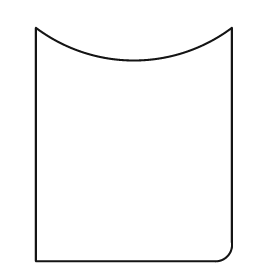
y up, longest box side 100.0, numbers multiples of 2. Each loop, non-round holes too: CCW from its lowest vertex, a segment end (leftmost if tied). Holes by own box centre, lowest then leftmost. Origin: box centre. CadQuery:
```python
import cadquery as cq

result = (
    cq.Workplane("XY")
    .moveTo(-42.0, -50.0)
    .lineTo(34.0, -50.0)
    .threePointArc((40.0, -48.0), (42.0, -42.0))
    .lineTo(42.0, 50.0)
    .threePointArc((0.0, 36.0), (-42.0, 50.0))
    .close()
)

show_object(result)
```